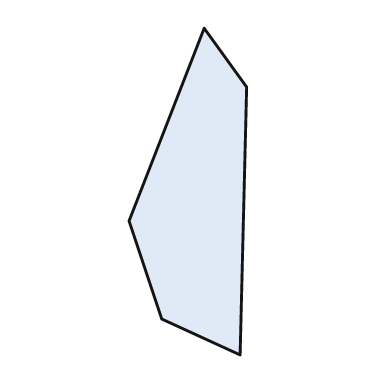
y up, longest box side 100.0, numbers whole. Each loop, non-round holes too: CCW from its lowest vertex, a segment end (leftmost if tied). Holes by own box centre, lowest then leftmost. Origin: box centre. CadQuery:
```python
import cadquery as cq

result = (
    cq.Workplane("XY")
    .moveTo(16.0, -50.0)
    .lineTo(18.0, 32.0)
    .lineTo(5.0, 50.0)
    .lineTo(-18.0, -9.0)
    .lineTo(-8.0, -39.0)
    .close()
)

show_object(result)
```